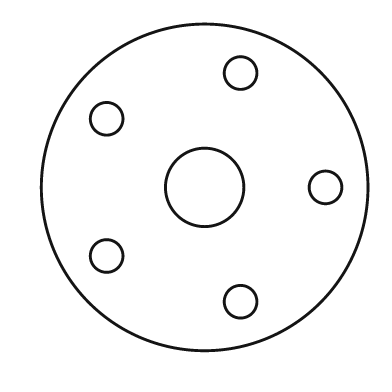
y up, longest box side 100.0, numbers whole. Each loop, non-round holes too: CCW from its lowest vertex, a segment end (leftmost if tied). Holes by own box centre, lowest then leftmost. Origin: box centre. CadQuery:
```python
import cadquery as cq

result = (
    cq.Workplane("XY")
    .moveTo(0.0, 0.0)
    .circle(50.0)
    .moveTo(11.0, -35.0)
    .circle(5.0)
    .moveTo(-30.0, -21.0)
    .circle(5.0)
    .moveTo(0.0, 0.0)
    .circle(12.0)
    .moveTo(37.0, 0.0)
    .circle(5.0)
    .moveTo(-30.0, 21.0)
    .circle(5.0)
    .moveTo(11.0, 35.0)
    .circle(5.0)
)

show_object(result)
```